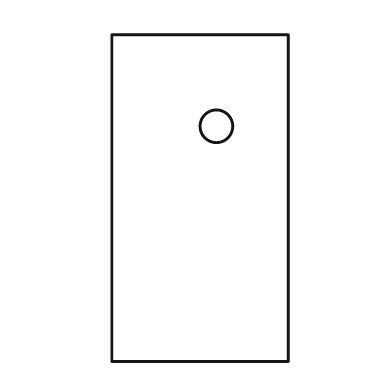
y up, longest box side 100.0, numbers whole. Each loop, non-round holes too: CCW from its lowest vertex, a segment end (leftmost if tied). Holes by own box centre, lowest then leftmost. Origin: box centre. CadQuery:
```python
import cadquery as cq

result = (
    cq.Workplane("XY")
    .moveTo(-27.0, -50.0)
    .lineTo(27.0, -50.0)
    .lineTo(27.0, 50.0)
    .lineTo(-27.0, 50.0)
    .close()
    .moveTo(5.0, 22.0)
    .circle(5.0)
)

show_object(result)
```